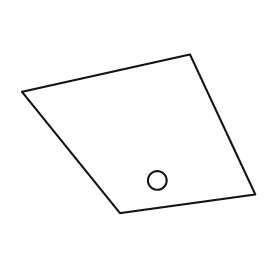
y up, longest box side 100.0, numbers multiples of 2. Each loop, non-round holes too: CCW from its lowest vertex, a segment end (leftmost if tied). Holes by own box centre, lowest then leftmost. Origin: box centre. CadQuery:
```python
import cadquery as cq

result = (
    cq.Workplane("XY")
    .moveTo(-8.0, -34.0)
    .lineTo(50.0, -26.0)
    .lineTo(22.0, 34.0)
    .lineTo(-50.0, 18.0)
    .close()
    .moveTo(8.0, -20.0)
    .circle(4.0)
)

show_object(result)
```